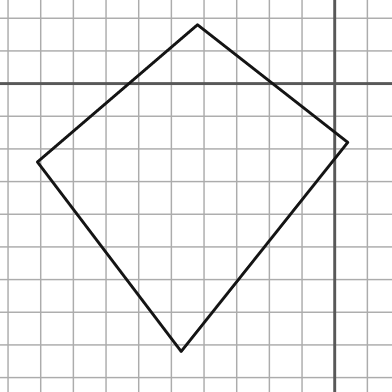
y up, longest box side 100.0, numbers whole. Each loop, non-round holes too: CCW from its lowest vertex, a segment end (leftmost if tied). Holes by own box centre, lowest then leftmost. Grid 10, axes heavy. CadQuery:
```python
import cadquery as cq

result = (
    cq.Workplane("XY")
    .moveTo(-47.0, -82.0)
    .lineTo(4.0, -18.0)
    .lineTo(-42.0, 18.0)
    .lineTo(-91.0, -24.0)
    .close()
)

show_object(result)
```